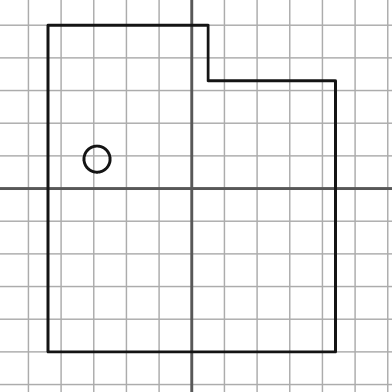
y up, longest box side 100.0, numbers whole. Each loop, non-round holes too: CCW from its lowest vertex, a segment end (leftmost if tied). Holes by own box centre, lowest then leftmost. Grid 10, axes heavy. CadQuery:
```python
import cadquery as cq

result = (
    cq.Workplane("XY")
    .moveTo(-44.0, -50.0)
    .lineTo(44.0, -50.0)
    .lineTo(44.0, 33.0)
    .lineTo(5.0, 33.0)
    .lineTo(5.0, 50.0)
    .lineTo(-44.0, 50.0)
    .close()
    .moveTo(-29.0, 9.0)
    .circle(4.0)
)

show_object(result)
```